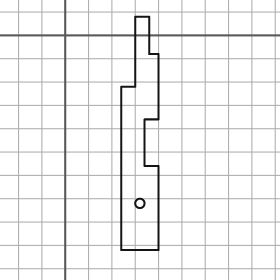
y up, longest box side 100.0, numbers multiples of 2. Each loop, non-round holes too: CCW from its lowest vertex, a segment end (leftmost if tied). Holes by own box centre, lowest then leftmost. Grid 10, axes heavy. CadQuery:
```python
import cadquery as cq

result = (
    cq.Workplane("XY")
    .moveTo(24.0, -92.0)
    .lineTo(40.0, -92.0)
    .lineTo(40.0, -56.0)
    .lineTo(34.0, -56.0)
    .lineTo(34.0, -36.0)
    .lineTo(40.0, -36.0)
    .lineTo(40.0, -8.0)
    .lineTo(36.0, -8.0)
    .lineTo(36.0, 8.0)
    .lineTo(30.0, 8.0)
    .lineTo(30.0, -22.0)
    .lineTo(24.0, -22.0)
    .close()
    .moveTo(32.0, -72.0)
    .circle(2.0)
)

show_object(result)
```